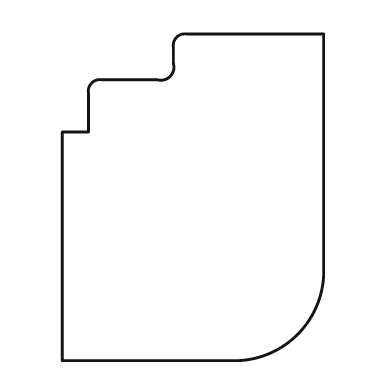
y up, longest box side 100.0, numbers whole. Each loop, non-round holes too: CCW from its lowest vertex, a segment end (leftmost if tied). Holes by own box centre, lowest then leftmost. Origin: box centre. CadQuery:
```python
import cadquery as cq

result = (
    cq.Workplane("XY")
    .moveTo(-40.0, -50.0)
    .lineTo(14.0, -50.0)
    .threePointArc((32.0, -42.0), (40.0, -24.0))
    .lineTo(40.0, 50.0)
    .lineTo(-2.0, 50.0)
    .threePointArc((-5.0, 49.0), (-6.0, 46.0))
    .lineTo(-6.0, 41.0)
    .threePointArc((-7.0, 37.0), (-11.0, 36.0))
    .lineTo(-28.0, 36.0)
    .threePointArc((-31.0, 35.0), (-32.0, 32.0))
    .lineTo(-32.0, 20.0)
    .lineTo(-40.0, 20.0)
    .close()
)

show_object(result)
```